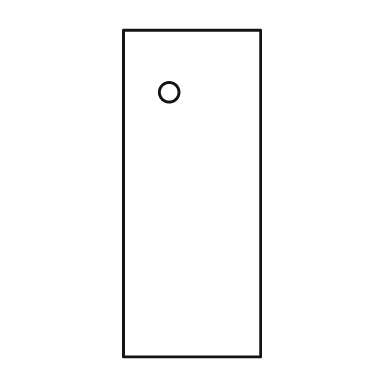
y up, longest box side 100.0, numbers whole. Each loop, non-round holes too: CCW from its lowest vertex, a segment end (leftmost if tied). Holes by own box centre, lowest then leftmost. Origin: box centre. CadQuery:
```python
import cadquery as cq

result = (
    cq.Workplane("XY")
    .moveTo(-21.0, -50.0)
    .lineTo(21.0, -50.0)
    .lineTo(21.0, 50.0)
    .lineTo(-21.0, 50.0)
    .close()
    .moveTo(-7.0, 31.0)
    .circle(3.0)
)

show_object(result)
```